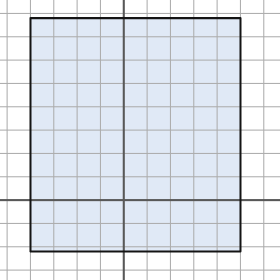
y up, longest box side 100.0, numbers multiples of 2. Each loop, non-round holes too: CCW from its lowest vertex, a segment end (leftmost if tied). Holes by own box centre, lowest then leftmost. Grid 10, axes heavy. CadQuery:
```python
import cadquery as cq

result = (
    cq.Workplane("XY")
    .moveTo(-40.0, -22.0)
    .lineTo(50.0, -22.0)
    .lineTo(50.0, 78.0)
    .lineTo(-40.0, 78.0)
    .close()
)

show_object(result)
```